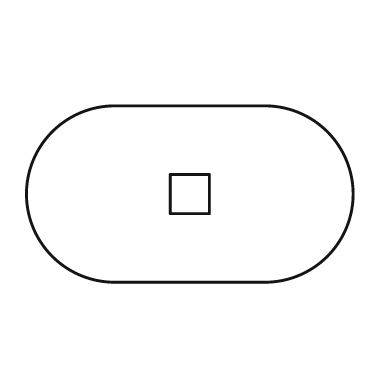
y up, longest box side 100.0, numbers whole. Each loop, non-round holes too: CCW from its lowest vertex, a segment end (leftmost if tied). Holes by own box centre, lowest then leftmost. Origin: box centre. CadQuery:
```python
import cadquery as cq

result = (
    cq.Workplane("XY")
    .moveTo(-23.0, -27.0)
    .lineTo(23.0, -27.0)
    .threePointArc((50.0, 0.0), (23.0, 27.0))
    .lineTo(-23.0, 27.0)
    .threePointArc((-50.0, 0.0), (-23.0, -27.0))
    .close()
    .moveTo(-6.0, -6.0)
    .lineTo(6.0, -6.0)
    .lineTo(6.0, 6.0)
    .lineTo(-6.0, 6.0)
    .close()
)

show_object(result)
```